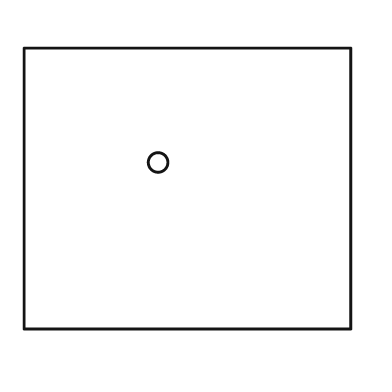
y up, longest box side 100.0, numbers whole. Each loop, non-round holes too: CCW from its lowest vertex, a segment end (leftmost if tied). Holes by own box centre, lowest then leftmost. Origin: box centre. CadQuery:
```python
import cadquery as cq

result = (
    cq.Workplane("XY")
    .moveTo(-50.0, -43.0)
    .lineTo(50.0, -43.0)
    .lineTo(50.0, 43.0)
    .lineTo(-50.0, 43.0)
    .close()
    .moveTo(-9.0, 8.0)
    .circle(3.0)
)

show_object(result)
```